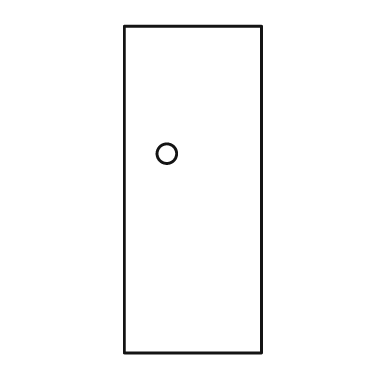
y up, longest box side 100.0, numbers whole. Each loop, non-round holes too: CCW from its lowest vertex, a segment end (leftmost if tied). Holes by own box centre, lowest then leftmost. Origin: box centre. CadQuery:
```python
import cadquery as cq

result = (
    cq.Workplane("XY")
    .moveTo(-21.0, -50.0)
    .lineTo(21.0, -50.0)
    .lineTo(21.0, 50.0)
    .lineTo(-21.0, 50.0)
    .close()
    .moveTo(-8.0, 11.0)
    .circle(3.0)
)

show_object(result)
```